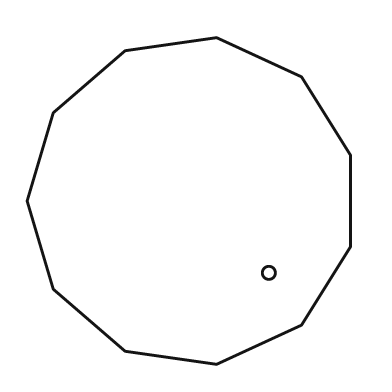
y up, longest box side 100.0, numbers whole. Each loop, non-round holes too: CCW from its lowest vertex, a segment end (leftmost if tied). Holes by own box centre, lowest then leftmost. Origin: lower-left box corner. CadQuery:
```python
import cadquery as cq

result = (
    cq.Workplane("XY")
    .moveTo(58.0, 0.0)
    .lineTo(84.0, 12.0)
    .lineTo(99.0, 36.0)
    .lineTo(99.0, 64.0)
    .lineTo(84.0, 88.0)
    .lineTo(58.0, 100.0)
    .lineTo(30.0, 96.0)
    .lineTo(8.0, 77.0)
    .lineTo(0.0, 50.0)
    .lineTo(8.0, 23.0)
    .lineTo(30.0, 4.0)
    .close()
    .moveTo(74.0, 28.0)
    .circle(2.0)
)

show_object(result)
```